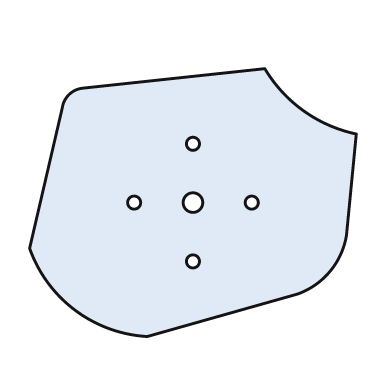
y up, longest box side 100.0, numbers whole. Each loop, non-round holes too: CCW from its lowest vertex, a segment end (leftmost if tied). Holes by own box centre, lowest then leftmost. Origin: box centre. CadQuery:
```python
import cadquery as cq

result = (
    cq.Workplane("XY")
    .moveTo(-14.0, -41.0)
    .lineTo(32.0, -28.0)
    .threePointArc((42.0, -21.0), (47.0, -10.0))
    .lineTo(50.0, 21.0)
    .threePointArc((34.0, 28.0), (22.0, 41.0))
    .lineTo(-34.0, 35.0)
    .threePointArc((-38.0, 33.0), (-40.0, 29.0))
    .lineTo(-50.0, -14.0)
    .threePointArc((-36.0, -33.0), (-14.0, -41.0))
    .close()
    .moveTo(0.0, -18.0)
    .circle(2.0)
    .moveTo(-18.0, 0.0)
    .circle(2.0)
    .moveTo(0.0, 0.0)
    .circle(3.0)
    .moveTo(18.0, 0.0)
    .circle(2.0)
    .moveTo(0.0, 18.0)
    .circle(2.0)
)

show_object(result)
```